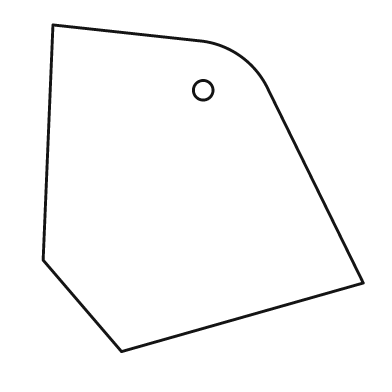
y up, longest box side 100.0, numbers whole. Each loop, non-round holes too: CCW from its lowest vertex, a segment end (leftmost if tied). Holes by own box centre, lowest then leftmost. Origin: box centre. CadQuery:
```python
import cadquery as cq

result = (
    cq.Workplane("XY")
    .moveTo(-25.0, -50.0)
    .lineTo(49.0, -29.0)
    .lineTo(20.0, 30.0)
    .threePointArc((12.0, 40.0), (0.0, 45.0))
    .lineTo(-46.0, 50.0)
    .lineTo(-49.0, -22.0)
    .close()
    .moveTo(0.0, 30.0)
    .circle(3.0)
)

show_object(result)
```